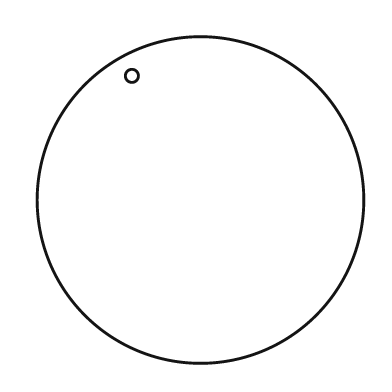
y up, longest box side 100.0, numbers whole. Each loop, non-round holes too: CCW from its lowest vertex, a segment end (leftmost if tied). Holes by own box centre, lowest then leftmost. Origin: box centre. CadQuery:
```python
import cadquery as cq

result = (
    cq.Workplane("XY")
    .moveTo(0.0, 0.0)
    .circle(50.0)
    .moveTo(-21.0, 38.0)
    .circle(2.0)
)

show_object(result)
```